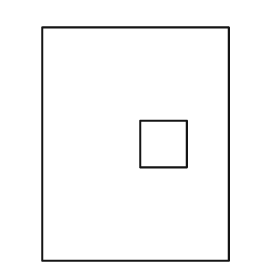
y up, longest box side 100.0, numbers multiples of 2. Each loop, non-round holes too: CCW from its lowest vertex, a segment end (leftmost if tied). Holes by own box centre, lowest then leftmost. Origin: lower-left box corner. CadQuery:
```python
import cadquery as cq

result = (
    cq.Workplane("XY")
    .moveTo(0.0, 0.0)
    .lineTo(80.0, 0.0)
    .lineTo(80.0, 100.0)
    .lineTo(0.0, 100.0)
    .close()
    .moveTo(42.0, 40.0)
    .lineTo(62.0, 40.0)
    .lineTo(62.0, 60.0)
    .lineTo(42.0, 60.0)
    .close()
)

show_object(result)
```